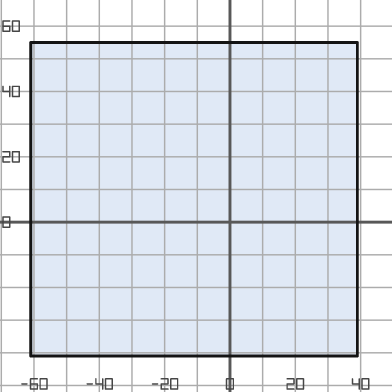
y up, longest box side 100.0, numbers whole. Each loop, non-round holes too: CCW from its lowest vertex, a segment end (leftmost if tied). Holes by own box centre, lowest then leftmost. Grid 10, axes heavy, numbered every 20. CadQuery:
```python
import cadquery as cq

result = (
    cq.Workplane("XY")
    .moveTo(-61.0, -41.0)
    .lineTo(39.0, -41.0)
    .lineTo(39.0, 55.0)
    .lineTo(-61.0, 55.0)
    .close()
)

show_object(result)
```